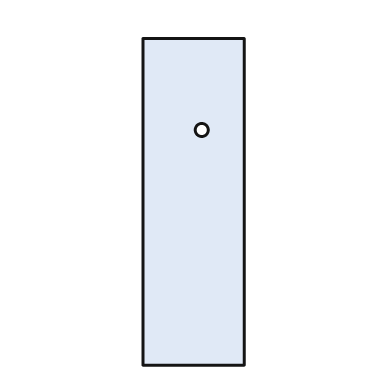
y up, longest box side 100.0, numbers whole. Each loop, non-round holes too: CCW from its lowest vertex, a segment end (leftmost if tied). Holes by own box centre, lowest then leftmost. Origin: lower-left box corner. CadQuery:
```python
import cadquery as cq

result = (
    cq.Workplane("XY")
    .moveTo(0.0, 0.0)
    .lineTo(31.0, 0.0)
    .lineTo(31.0, 100.0)
    .lineTo(0.0, 100.0)
    .close()
    .moveTo(18.0, 72.0)
    .circle(2.0)
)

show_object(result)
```